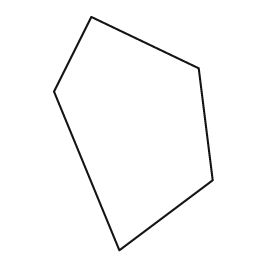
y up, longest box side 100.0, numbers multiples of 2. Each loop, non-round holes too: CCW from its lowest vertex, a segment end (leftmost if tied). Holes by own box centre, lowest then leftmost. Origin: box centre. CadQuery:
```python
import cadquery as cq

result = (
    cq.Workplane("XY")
    .moveTo(-6.0, -50.0)
    .lineTo(34.0, -20.0)
    .lineTo(28.0, 28.0)
    .lineTo(-18.0, 50.0)
    .lineTo(-34.0, 18.0)
    .close()
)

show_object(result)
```